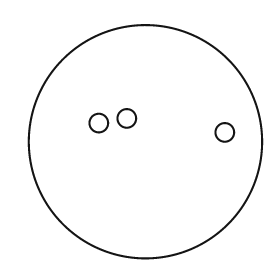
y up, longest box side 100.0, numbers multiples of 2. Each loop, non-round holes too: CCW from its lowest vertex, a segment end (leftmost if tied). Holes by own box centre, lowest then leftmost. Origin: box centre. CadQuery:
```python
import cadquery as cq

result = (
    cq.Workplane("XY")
    .moveTo(0.0, 0.0)
    .circle(50.0)
    .moveTo(34.0, 4.0)
    .circle(4.0)
    .moveTo(-20.0, 8.0)
    .circle(4.0)
    .moveTo(-8.0, 10.0)
    .circle(4.0)
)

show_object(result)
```